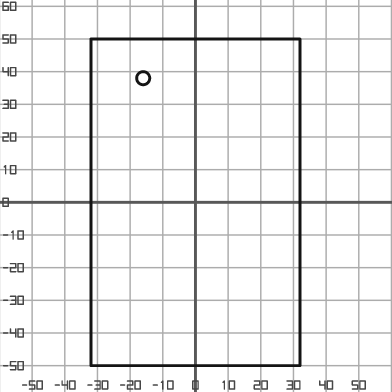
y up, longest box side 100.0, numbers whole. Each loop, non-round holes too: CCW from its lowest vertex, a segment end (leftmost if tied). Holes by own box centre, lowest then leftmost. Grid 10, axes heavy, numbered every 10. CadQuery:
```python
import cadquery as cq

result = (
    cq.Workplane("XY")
    .moveTo(-32.0, -50.0)
    .lineTo(32.0, -50.0)
    .lineTo(32.0, 50.0)
    .lineTo(-32.0, 50.0)
    .close()
    .moveTo(-16.0, 38.0)
    .circle(2.0)
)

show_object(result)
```